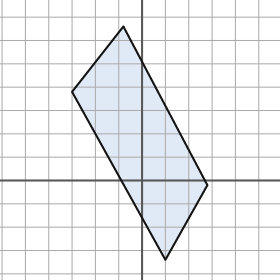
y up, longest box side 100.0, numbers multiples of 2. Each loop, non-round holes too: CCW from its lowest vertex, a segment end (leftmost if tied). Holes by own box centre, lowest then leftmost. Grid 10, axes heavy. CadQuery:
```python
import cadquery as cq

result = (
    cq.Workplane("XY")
    .moveTo(10.0, -34.0)
    .lineTo(28.0, -2.0)
    .lineTo(-8.0, 66.0)
    .lineTo(-30.0, 38.0)
    .close()
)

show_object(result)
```